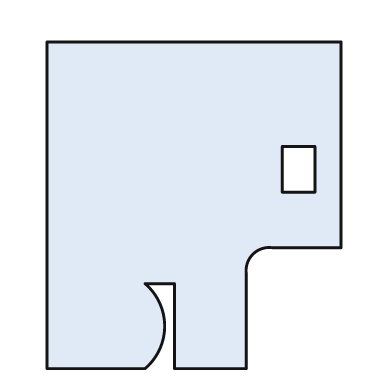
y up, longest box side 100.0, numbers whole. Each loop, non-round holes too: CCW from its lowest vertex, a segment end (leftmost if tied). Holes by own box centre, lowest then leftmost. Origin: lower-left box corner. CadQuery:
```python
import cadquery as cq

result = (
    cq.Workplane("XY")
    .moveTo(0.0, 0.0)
    .lineTo(30.0, 0.0)
    .threePointArc((36.0, 13.0), (30.0, 26.0))
    .lineTo(39.0, 26.0)
    .lineTo(39.0, 0.0)
    .lineTo(61.0, 0.0)
    .lineTo(61.0, 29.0)
    .threePointArc((63.0, 35.0), (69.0, 37.0))
    .lineTo(90.0, 37.0)
    .lineTo(90.0, 100.0)
    .lineTo(0.0, 100.0)
    .close()
    .moveTo(72.0, 54.0)
    .lineTo(82.0, 54.0)
    .lineTo(82.0, 68.0)
    .lineTo(72.0, 68.0)
    .close()
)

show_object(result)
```